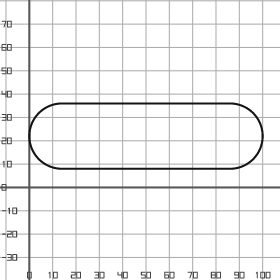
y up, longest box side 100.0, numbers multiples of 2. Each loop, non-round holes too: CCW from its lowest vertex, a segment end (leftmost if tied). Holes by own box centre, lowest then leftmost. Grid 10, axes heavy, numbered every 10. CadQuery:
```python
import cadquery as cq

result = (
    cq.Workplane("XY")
    .moveTo(14.0, 8.0)
    .lineTo(86.0, 8.0)
    .threePointArc((100.0, 22.0), (86.0, 36.0))
    .lineTo(14.0, 36.0)
    .threePointArc((0.0, 22.0), (14.0, 8.0))
    .close()
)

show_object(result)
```